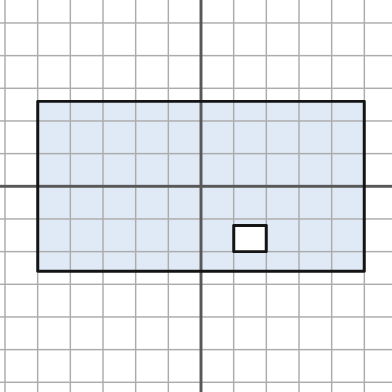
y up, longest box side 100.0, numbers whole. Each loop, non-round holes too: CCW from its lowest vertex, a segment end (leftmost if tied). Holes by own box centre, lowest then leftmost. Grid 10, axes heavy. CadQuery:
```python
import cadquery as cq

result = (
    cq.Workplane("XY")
    .moveTo(-50.0, -26.0)
    .lineTo(50.0, -26.0)
    .lineTo(50.0, 26.0)
    .lineTo(-50.0, 26.0)
    .close()
    .moveTo(10.0, -20.0)
    .lineTo(20.0, -20.0)
    .lineTo(20.0, -12.0)
    .lineTo(10.0, -12.0)
    .close()
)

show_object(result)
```